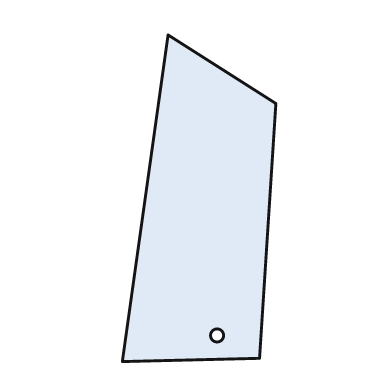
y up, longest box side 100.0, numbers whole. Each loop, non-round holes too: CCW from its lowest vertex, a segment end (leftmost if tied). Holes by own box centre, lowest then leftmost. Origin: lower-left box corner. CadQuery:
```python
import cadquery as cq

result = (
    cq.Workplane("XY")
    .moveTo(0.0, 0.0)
    .lineTo(42.0, 1.0)
    .lineTo(47.0, 79.0)
    .lineTo(14.0, 100.0)
    .close()
    .moveTo(29.0, 8.0)
    .circle(2.0)
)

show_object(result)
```